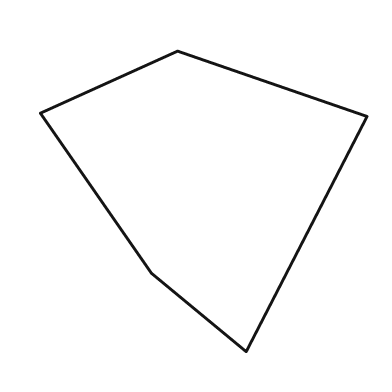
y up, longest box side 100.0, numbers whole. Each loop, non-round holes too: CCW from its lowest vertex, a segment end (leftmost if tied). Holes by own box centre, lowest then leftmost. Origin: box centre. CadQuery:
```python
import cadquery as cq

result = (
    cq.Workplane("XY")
    .moveTo(13.0, -46.0)
    .lineTo(50.0, 26.0)
    .lineTo(-8.0, 46.0)
    .lineTo(-50.0, 27.0)
    .lineTo(-16.0, -22.0)
    .close()
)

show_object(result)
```